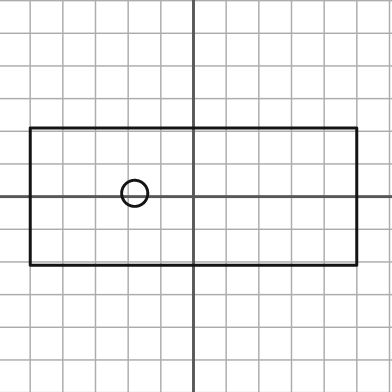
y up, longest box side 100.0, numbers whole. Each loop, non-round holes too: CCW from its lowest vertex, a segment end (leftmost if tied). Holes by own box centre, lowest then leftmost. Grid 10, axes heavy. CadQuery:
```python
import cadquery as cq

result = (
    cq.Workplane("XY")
    .moveTo(-50.0, -21.0)
    .lineTo(50.0, -21.0)
    .lineTo(50.0, 21.0)
    .lineTo(-50.0, 21.0)
    .close()
    .moveTo(-18.0, 1.0)
    .circle(4.0)
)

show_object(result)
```